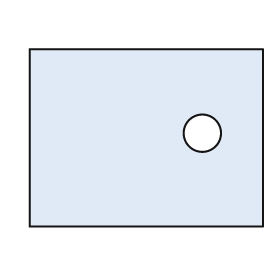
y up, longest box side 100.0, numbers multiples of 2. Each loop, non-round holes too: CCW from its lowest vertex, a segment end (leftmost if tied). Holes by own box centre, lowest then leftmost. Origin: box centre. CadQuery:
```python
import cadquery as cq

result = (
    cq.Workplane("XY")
    .moveTo(-50.0, -38.0)
    .lineTo(50.0, -38.0)
    .lineTo(50.0, 38.0)
    .lineTo(-50.0, 38.0)
    .close()
    .moveTo(24.0, 2.0)
    .circle(8.0)
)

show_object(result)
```